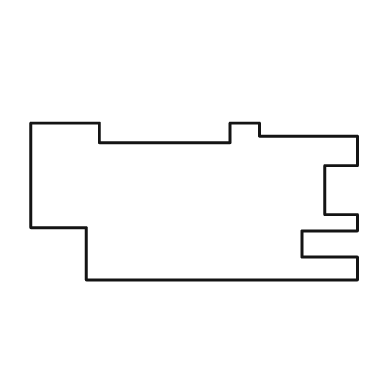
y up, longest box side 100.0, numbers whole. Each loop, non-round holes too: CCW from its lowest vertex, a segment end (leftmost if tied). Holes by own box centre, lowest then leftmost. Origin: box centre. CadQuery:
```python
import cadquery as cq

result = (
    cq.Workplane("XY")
    .moveTo(-33.0, -24.0)
    .lineTo(50.0, -24.0)
    .lineTo(50.0, -17.0)
    .lineTo(33.0, -17.0)
    .lineTo(33.0, -9.0)
    .lineTo(50.0, -9.0)
    .lineTo(50.0, -4.0)
    .lineTo(40.0, -4.0)
    .lineTo(40.0, 11.0)
    .lineTo(50.0, 11.0)
    .lineTo(50.0, 20.0)
    .lineTo(20.0, 20.0)
    .lineTo(20.0, 24.0)
    .lineTo(11.0, 24.0)
    .lineTo(11.0, 18.0)
    .lineTo(-29.0, 18.0)
    .lineTo(-29.0, 24.0)
    .lineTo(-50.0, 24.0)
    .lineTo(-50.0, -8.0)
    .lineTo(-33.0, -8.0)
    .close()
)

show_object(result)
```